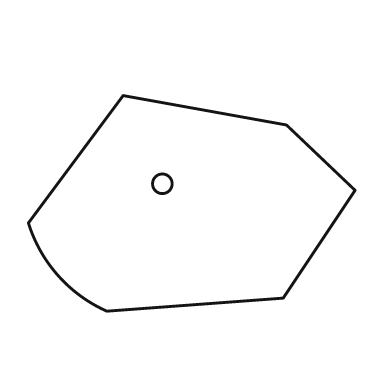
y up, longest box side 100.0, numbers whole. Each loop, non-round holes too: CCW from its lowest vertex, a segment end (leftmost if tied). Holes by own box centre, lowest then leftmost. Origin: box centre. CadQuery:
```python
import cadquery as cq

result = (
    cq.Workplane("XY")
    .moveTo(-26.0, -33.0)
    .lineTo(28.0, -29.0)
    .lineTo(50.0, 4.0)
    .lineTo(29.0, 24.0)
    .lineTo(-21.0, 33.0)
    .lineTo(-50.0, -6.0)
    .threePointArc((-41.0, -22.0), (-26.0, -33.0))
    .close()
    .moveTo(-9.0, 6.0)
    .circle(3.0)
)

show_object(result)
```